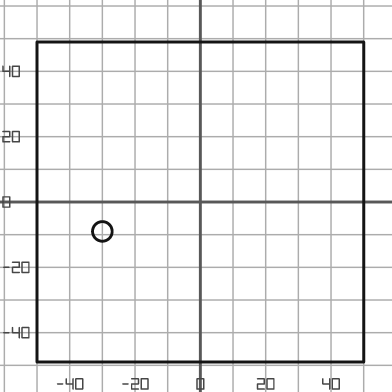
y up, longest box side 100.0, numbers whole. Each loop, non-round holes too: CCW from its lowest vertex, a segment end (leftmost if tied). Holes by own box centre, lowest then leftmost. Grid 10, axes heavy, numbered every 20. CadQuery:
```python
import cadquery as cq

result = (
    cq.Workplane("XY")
    .moveTo(-50.0, -49.0)
    .lineTo(50.0, -49.0)
    .lineTo(50.0, 49.0)
    .lineTo(-50.0, 49.0)
    .close()
    .moveTo(-30.0, -9.0)
    .circle(3.0)
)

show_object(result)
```